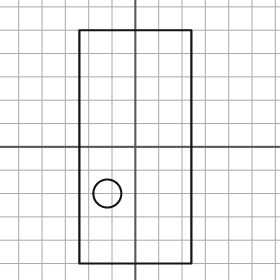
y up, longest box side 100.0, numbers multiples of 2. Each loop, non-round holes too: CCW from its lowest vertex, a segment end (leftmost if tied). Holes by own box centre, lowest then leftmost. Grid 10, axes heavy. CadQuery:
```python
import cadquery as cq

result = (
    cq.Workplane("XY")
    .moveTo(-24.0, -50.0)
    .lineTo(24.0, -50.0)
    .lineTo(24.0, 50.0)
    .lineTo(-24.0, 50.0)
    .close()
    .moveTo(-12.0, -20.0)
    .circle(6.0)
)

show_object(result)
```